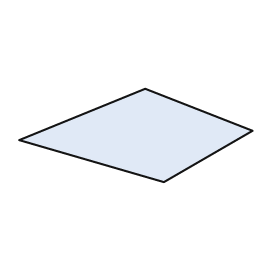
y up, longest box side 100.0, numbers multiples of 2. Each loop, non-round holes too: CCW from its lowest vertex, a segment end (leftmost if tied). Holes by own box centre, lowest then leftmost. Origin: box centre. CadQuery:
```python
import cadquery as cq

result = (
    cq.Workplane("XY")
    .moveTo(12.0, -20.0)
    .lineTo(50.0, 2.0)
    .lineTo(4.0, 20.0)
    .lineTo(-50.0, -2.0)
    .close()
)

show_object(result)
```